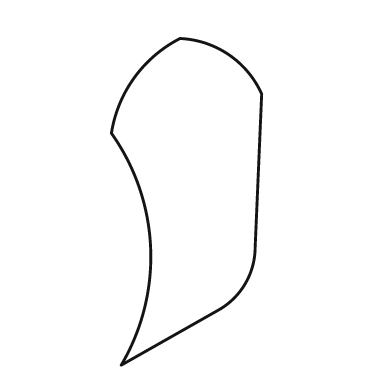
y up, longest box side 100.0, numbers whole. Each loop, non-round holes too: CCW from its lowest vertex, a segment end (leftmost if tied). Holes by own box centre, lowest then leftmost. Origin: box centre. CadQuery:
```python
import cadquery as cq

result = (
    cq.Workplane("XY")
    .moveTo(-20.0, -50.0)
    .lineTo(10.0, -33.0)
    .threePointArc((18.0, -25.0), (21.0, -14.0))
    .lineTo(23.0, 33.0)
    .threePointArc((13.0, 45.0), (-2.0, 50.0))
    .threePointArc((-16.0, 38.0), (-23.0, 21.0))
    .threePointArc((-11.0, -14.0), (-20.0, -50.0))
    .close()
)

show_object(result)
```